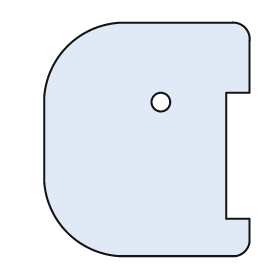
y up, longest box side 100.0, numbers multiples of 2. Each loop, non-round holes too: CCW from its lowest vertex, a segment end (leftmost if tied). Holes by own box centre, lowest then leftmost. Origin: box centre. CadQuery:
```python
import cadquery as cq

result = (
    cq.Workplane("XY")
    .moveTo(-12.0, -50.0)
    .lineTo(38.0, -50.0)
    .threePointArc((42.0, -48.0), (44.0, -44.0))
    .lineTo(44.0, -34.0)
    .lineTo(34.0, -34.0)
    .lineTo(34.0, 20.0)
    .lineTo(44.0, 20.0)
    .lineTo(44.0, 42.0)
    .threePointArc((42.0, 48.0), (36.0, 50.0))
    .lineTo(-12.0, 50.0)
    .threePointArc((-34.0, 40.0), (-44.0, 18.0))
    .lineTo(-44.0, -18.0)
    .threePointArc((-34.0, -40.0), (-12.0, -50.0))
    .close()
    .moveTo(6.0, 16.0)
    .circle(4.0)
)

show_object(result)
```